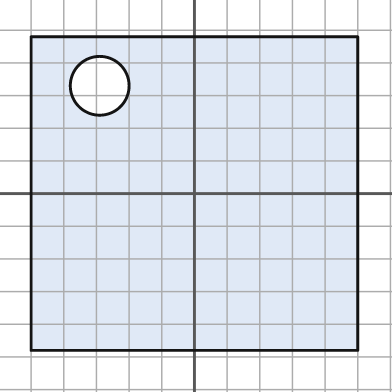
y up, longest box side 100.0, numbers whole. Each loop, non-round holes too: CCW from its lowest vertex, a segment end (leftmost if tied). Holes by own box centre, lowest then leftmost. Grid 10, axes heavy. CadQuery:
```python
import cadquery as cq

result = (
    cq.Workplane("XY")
    .moveTo(-50.0, -48.0)
    .lineTo(50.0, -48.0)
    .lineTo(50.0, 48.0)
    .lineTo(-50.0, 48.0)
    .close()
    .moveTo(-29.0, 33.0)
    .circle(9.0)
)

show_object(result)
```